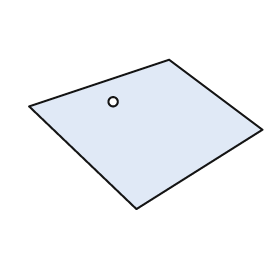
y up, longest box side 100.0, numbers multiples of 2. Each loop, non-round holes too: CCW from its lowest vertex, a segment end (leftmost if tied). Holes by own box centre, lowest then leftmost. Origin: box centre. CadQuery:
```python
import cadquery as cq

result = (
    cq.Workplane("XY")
    .moveTo(-4.0, -32.0)
    .lineTo(50.0, 2.0)
    .lineTo(10.0, 32.0)
    .lineTo(-50.0, 12.0)
    .close()
    .moveTo(-14.0, 14.0)
    .circle(2.0)
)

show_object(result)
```